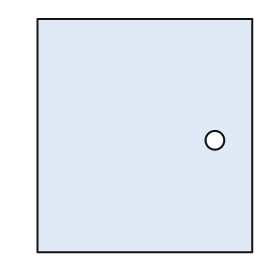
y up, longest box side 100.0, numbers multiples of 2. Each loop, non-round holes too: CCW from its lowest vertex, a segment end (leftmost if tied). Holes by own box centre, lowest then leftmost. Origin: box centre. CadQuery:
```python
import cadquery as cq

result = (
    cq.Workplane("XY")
    .moveTo(-46.0, -50.0)
    .lineTo(46.0, -50.0)
    .lineTo(46.0, 50.0)
    .lineTo(-46.0, 50.0)
    .close()
    .moveTo(30.0, -2.0)
    .circle(4.0)
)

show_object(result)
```